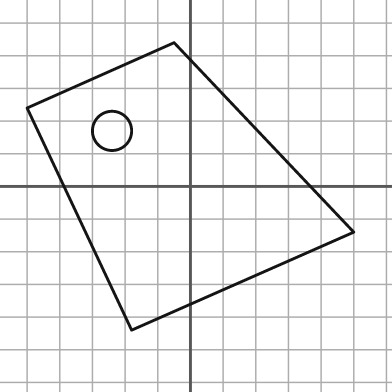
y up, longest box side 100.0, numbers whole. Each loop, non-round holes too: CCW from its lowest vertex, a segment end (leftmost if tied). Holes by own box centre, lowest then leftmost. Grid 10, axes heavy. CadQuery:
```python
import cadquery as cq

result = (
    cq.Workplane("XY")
    .moveTo(-18.0, -44.0)
    .lineTo(50.0, -14.0)
    .lineTo(-5.0, 44.0)
    .lineTo(-50.0, 24.0)
    .close()
    .moveTo(-24.0, 17.0)
    .circle(6.0)
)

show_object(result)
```